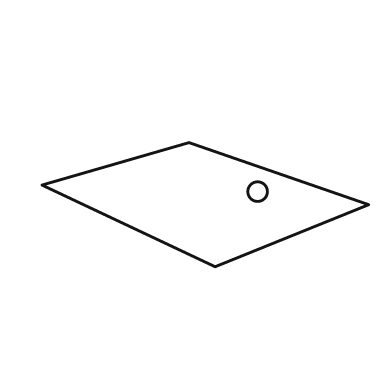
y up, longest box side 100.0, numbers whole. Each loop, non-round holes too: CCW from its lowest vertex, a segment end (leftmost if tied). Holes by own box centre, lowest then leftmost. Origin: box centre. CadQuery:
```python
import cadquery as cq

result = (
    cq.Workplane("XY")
    .moveTo(3.0, -19.0)
    .lineTo(50.0, 0.0)
    .lineTo(-5.0, 19.0)
    .lineTo(-50.0, 6.0)
    .close()
    .moveTo(16.0, 4.0)
    .circle(3.0)
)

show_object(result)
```